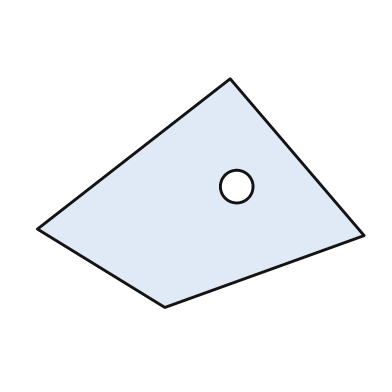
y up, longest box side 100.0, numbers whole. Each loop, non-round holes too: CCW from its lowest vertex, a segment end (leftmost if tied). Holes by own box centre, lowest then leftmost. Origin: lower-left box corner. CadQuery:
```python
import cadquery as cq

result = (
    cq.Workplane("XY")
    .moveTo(39.0, 0.0)
    .lineTo(100.0, 22.0)
    .lineTo(59.0, 70.0)
    .lineTo(0.0, 24.0)
    .close()
    .moveTo(61.0, 37.0)
    .circle(5.0)
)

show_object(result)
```